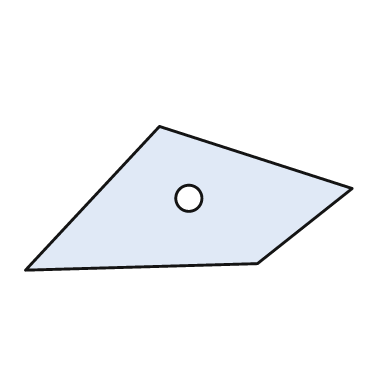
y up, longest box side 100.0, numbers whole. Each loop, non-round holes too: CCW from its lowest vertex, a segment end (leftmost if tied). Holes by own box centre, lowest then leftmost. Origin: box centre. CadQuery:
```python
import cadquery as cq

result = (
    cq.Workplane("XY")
    .moveTo(-50.0, -22.0)
    .lineTo(21.0, -20.0)
    .lineTo(50.0, 3.0)
    .lineTo(-9.0, 22.0)
    .close()
    .moveTo(0.0, 0.0)
    .circle(4.0)
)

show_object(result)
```